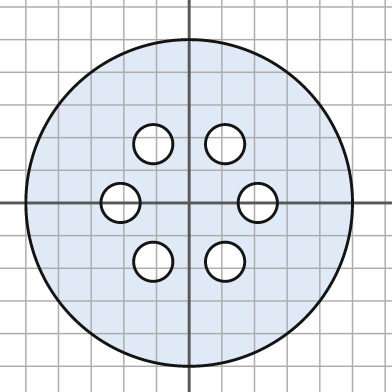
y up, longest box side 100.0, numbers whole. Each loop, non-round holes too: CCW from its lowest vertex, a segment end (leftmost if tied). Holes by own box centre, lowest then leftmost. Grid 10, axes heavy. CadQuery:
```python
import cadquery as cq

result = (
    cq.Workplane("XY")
    .moveTo(0.0, 0.0)
    .circle(50.0)
    .moveTo(-11.0, -18.0)
    .circle(6.0)
    .moveTo(11.0, -18.0)
    .circle(6.0)
    .moveTo(-21.0, 0.0)
    .circle(6.0)
    .moveTo(21.0, 0.0)
    .circle(6.0)
    .moveTo(-11.0, 18.0)
    .circle(6.0)
    .moveTo(11.0, 18.0)
    .circle(6.0)
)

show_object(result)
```